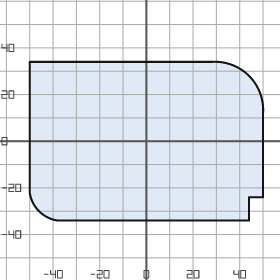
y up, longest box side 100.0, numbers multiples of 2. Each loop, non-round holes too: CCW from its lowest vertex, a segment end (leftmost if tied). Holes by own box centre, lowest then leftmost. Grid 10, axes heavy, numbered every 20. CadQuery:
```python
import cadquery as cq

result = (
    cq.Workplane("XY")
    .moveTo(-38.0, -34.0)
    .lineTo(44.0, -34.0)
    .lineTo(44.0, -24.0)
    .lineTo(50.0, -24.0)
    .lineTo(50.0, 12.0)
    .threePointArc((44.0, 28.0), (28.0, 34.0))
    .lineTo(-50.0, 34.0)
    .lineTo(-50.0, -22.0)
    .threePointArc((-46.0, -30.0), (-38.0, -34.0))
    .close()
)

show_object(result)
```